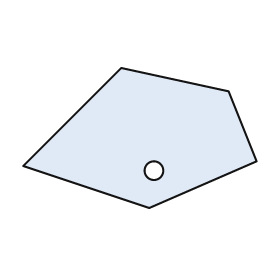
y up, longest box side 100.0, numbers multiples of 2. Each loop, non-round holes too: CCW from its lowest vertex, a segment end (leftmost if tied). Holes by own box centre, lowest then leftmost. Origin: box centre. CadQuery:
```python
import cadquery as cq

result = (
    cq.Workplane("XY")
    .moveTo(4.0, -30.0)
    .lineTo(50.0, -10.0)
    .lineTo(38.0, 20.0)
    .lineTo(-8.0, 30.0)
    .lineTo(-50.0, -12.0)
    .close()
    .moveTo(6.0, -14.0)
    .circle(4.0)
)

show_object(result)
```